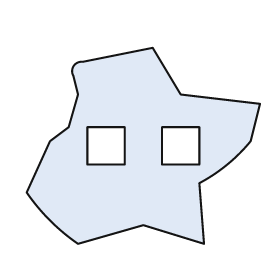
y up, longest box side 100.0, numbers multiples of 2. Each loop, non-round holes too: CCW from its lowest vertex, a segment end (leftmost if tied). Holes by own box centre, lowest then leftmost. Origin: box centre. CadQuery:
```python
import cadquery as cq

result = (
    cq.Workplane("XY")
    .moveTo(-28.0, -42.0)
    .lineTo(0.0, -34.0)
    .lineTo(26.0, -42.0)
    .lineTo(24.0, -16.0)
    .threePointArc((36.0, -8.0), (46.0, 2.0))
    .lineTo(50.0, 18.0)
    .lineTo(16.0, 22.0)
    .lineTo(4.0, 42.0)
    .lineTo(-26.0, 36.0)
    .threePointArc((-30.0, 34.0), (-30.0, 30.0))
    .lineTo(-28.0, 22.0)
    .lineTo(-32.0, 8.0)
    .lineTo(-40.0, 2.0)
    .lineTo(-50.0, -20.0)
    .threePointArc((-40.0, -32.0), (-28.0, -42.0))
    .close()
    .moveTo(-24.0, -8.0)
    .lineTo(-8.0, -8.0)
    .lineTo(-8.0, 8.0)
    .lineTo(-24.0, 8.0)
    .close()
    .moveTo(8.0, -8.0)
    .lineTo(24.0, -8.0)
    .lineTo(24.0, 8.0)
    .lineTo(8.0, 8.0)
    .close()
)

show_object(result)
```